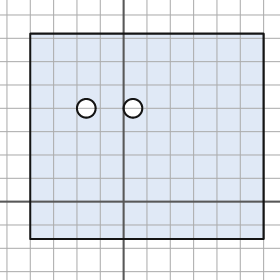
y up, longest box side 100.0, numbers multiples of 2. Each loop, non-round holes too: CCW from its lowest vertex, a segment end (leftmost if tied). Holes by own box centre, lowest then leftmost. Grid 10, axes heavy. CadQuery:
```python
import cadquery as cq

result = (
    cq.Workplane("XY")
    .moveTo(-40.0, -16.0)
    .lineTo(60.0, -16.0)
    .lineTo(60.0, 72.0)
    .lineTo(-40.0, 72.0)
    .close()
    .moveTo(-16.0, 40.0)
    .circle(4.0)
    .moveTo(4.0, 40.0)
    .circle(4.0)
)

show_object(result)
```